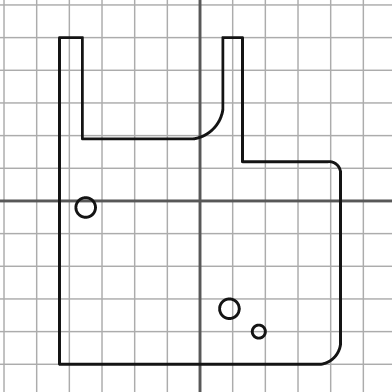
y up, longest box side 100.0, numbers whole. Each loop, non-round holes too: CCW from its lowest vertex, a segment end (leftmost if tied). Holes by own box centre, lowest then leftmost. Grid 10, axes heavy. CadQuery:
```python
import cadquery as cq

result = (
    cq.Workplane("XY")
    .moveTo(-43.0, -50.0)
    .lineTo(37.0, -50.0)
    .threePointArc((41.0, -48.0), (43.0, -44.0))
    .lineTo(43.0, 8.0)
    .threePointArc((42.0, 11.0), (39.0, 12.0))
    .lineTo(13.0, 12.0)
    .lineTo(13.0, 50.0)
    .lineTo(7.0, 50.0)
    .lineTo(7.0, 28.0)
    .threePointArc((4.0, 22.0), (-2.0, 19.0))
    .lineTo(-36.0, 19.0)
    .lineTo(-36.0, 50.0)
    .lineTo(-43.0, 50.0)
    .close()
    .moveTo(18.0, -40.0)
    .circle(2.0)
    .moveTo(9.0, -33.0)
    .circle(3.0)
    .moveTo(-35.0, -2.0)
    .circle(3.0)
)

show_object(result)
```